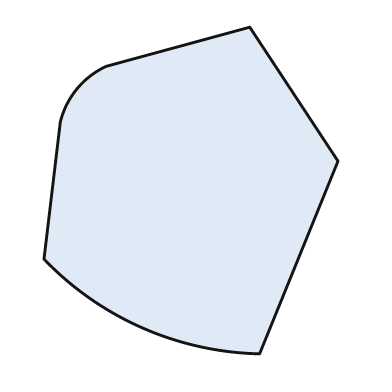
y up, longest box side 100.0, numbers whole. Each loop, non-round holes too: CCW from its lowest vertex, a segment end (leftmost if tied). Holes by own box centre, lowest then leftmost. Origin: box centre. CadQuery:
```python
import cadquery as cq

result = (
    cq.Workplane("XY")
    .moveTo(21.0, -50.0)
    .lineTo(45.0, 9.0)
    .lineTo(18.0, 50.0)
    .lineTo(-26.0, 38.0)
    .threePointArc((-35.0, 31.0), (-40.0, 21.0))
    .lineTo(-45.0, -21.0)
    .threePointArc((-15.0, -42.0), (21.0, -50.0))
    .close()
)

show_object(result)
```